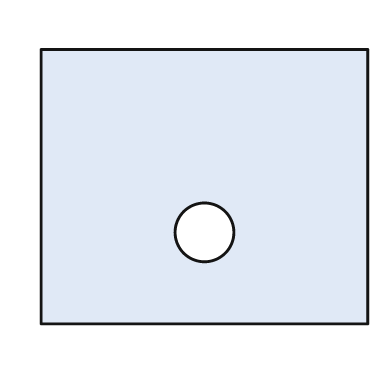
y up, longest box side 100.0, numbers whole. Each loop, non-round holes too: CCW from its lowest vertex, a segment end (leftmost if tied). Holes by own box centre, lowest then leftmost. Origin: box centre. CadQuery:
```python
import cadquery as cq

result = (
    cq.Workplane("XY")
    .moveTo(-50.0, -42.0)
    .lineTo(50.0, -42.0)
    .lineTo(50.0, 42.0)
    .lineTo(-50.0, 42.0)
    .close()
    .moveTo(0.0, -14.0)
    .circle(9.0)
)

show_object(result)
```